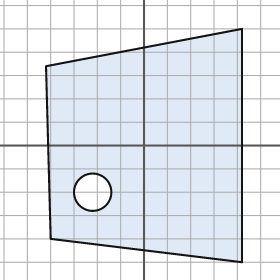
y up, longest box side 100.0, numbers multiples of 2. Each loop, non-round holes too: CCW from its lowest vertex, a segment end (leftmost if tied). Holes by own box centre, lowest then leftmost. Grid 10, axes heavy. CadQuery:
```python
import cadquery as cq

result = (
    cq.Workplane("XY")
    .moveTo(42.0, -50.0)
    .lineTo(42.0, 50.0)
    .lineTo(-42.0, 34.0)
    .lineTo(-40.0, -40.0)
    .close()
    .moveTo(-22.0, -20.0)
    .circle(8.0)
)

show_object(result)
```